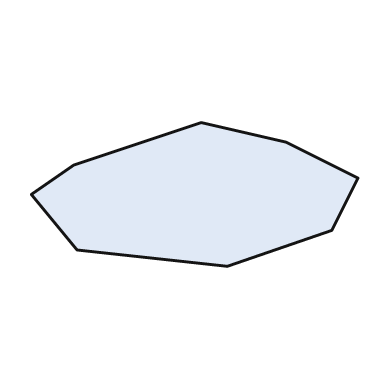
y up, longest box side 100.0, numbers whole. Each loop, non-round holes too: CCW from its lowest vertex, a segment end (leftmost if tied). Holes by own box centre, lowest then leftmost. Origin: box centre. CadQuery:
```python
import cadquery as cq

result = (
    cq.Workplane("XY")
    .moveTo(10.0, -22.0)
    .lineTo(42.0, -11.0)
    .lineTo(50.0, 5.0)
    .lineTo(28.0, 16.0)
    .lineTo(2.0, 22.0)
    .lineTo(-37.0, 9.0)
    .lineTo(-50.0, 0.0)
    .lineTo(-36.0, -17.0)
    .close()
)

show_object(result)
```